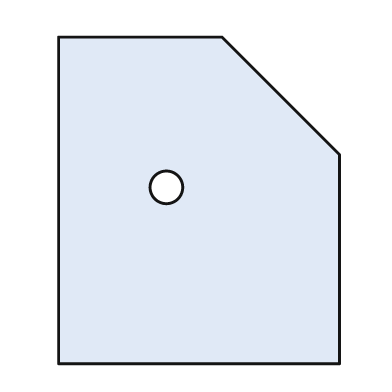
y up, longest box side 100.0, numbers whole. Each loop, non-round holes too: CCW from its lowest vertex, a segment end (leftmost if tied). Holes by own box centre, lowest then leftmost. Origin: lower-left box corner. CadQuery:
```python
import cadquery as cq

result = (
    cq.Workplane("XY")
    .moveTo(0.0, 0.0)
    .lineTo(86.0, 0.0)
    .lineTo(86.0, 64.0)
    .lineTo(50.0, 100.0)
    .lineTo(0.0, 100.0)
    .close()
    .moveTo(33.0, 54.0)
    .circle(5.0)
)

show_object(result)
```